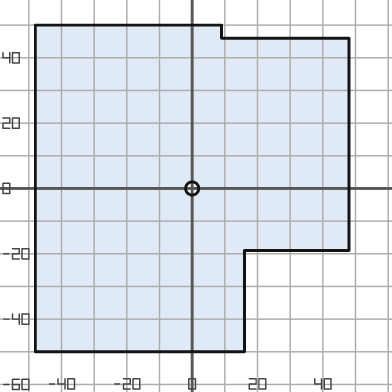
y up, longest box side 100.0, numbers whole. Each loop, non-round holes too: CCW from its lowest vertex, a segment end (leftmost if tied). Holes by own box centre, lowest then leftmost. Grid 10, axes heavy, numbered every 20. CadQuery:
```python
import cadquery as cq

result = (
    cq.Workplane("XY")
    .moveTo(-48.0, -50.0)
    .lineTo(16.0, -50.0)
    .lineTo(16.0, -19.0)
    .lineTo(48.0, -19.0)
    .lineTo(48.0, 46.0)
    .lineTo(9.0, 46.0)
    .lineTo(9.0, 50.0)
    .lineTo(-48.0, 50.0)
    .close()
    .moveTo(0.0, 0.0)
    .circle(2.0)
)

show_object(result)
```